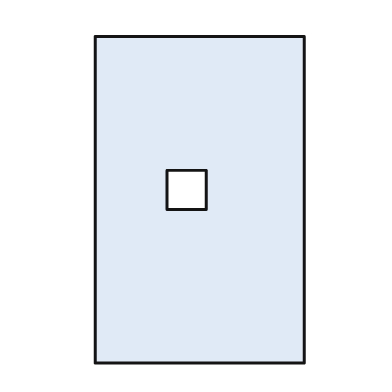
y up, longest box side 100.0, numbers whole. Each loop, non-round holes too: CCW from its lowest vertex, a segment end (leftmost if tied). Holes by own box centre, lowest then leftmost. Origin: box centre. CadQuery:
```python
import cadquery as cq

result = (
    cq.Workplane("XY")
    .moveTo(-32.0, -50.0)
    .lineTo(32.0, -50.0)
    .lineTo(32.0, 50.0)
    .lineTo(-32.0, 50.0)
    .close()
    .moveTo(-10.0, -3.0)
    .lineTo(2.0, -3.0)
    .lineTo(2.0, 9.0)
    .lineTo(-10.0, 9.0)
    .close()
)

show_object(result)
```